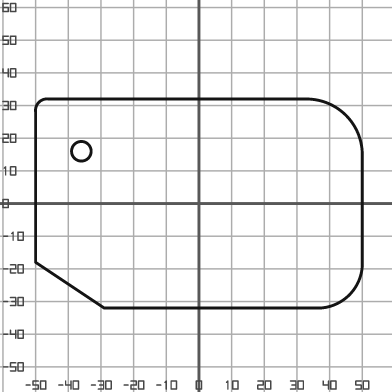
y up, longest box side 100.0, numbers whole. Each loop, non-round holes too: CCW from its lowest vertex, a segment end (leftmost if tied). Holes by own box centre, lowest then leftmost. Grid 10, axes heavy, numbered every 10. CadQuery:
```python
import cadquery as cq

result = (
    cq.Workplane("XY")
    .moveTo(-29.0, -32.0)
    .lineTo(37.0, -32.0)
    .threePointArc((46.0, -28.0), (50.0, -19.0))
    .lineTo(50.0, 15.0)
    .threePointArc((45.0, 27.0), (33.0, 32.0))
    .lineTo(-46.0, 32.0)
    .threePointArc((-49.0, 31.0), (-50.0, 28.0))
    .lineTo(-50.0, -18.0)
    .close()
    .moveTo(-36.0, 16.0)
    .circle(3.0)
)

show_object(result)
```